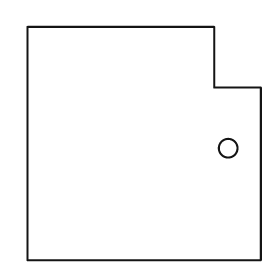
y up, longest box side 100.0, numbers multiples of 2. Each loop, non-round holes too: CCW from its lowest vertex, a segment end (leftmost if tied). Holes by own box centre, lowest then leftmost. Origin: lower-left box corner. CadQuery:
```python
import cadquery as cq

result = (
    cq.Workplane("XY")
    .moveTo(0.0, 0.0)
    .lineTo(100.0, 0.0)
    .lineTo(100.0, 74.0)
    .lineTo(80.0, 74.0)
    .lineTo(80.0, 100.0)
    .lineTo(0.0, 100.0)
    .close()
    .moveTo(86.0, 48.0)
    .circle(4.0)
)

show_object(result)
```